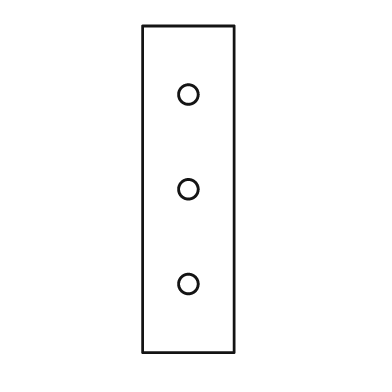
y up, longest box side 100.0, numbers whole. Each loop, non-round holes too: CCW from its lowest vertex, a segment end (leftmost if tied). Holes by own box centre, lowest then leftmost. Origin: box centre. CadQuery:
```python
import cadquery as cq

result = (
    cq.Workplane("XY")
    .moveTo(-14.0, -50.0)
    .lineTo(14.0, -50.0)
    .lineTo(14.0, 50.0)
    .lineTo(-14.0, 50.0)
    .close()
    .moveTo(0.0, -29.0)
    .circle(3.0)
    .moveTo(0.0, 0.0)
    .circle(3.0)
    .moveTo(0.0, 29.0)
    .circle(3.0)
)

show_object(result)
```